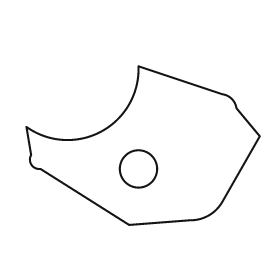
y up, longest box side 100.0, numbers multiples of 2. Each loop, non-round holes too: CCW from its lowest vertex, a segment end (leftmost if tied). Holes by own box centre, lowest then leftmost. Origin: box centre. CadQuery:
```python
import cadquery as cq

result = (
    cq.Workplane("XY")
    .moveTo(-6.0, -34.0)
    .lineTo(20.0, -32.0)
    .threePointArc((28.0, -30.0), (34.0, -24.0))
    .lineTo(50.0, 4.0)
    .lineTo(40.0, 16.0)
    .threePointArc((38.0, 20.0), (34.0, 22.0))
    .lineTo(-2.0, 34.0)
    .threePointArc((-18.0, 6.0), (-50.0, 8.0))
    .lineTo(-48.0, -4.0)
    .threePointArc((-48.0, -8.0), (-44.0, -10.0))
    .close()
    .moveTo(-2.0, -10.0)
    .circle(8.0)
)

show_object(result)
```